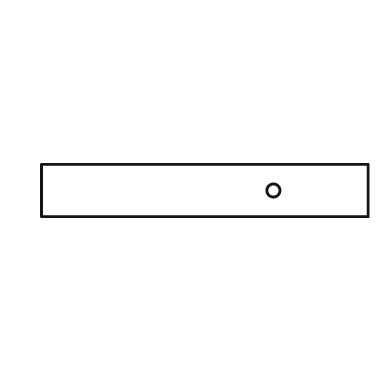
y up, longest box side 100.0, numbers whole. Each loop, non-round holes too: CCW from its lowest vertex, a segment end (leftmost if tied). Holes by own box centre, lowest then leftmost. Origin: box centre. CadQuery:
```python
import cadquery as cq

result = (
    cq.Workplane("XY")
    .moveTo(-50.0, -8.0)
    .lineTo(50.0, -8.0)
    .lineTo(50.0, 8.0)
    .lineTo(-50.0, 8.0)
    .close()
    .moveTo(21.0, 0.0)
    .circle(2.0)
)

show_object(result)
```